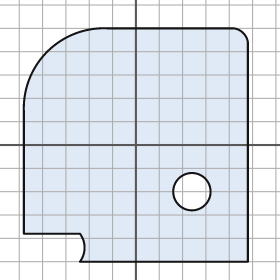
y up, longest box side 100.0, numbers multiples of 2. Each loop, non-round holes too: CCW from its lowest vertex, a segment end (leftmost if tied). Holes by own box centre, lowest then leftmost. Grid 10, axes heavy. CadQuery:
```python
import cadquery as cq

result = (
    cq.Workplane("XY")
    .moveTo(-24.0, -50.0)
    .lineTo(48.0, -50.0)
    .lineTo(48.0, 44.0)
    .threePointArc((46.0, 48.0), (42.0, 50.0))
    .lineTo(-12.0, 50.0)
    .threePointArc((-38.0, 40.0), (-48.0, 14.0))
    .lineTo(-48.0, -38.0)
    .lineTo(-24.0, -38.0)
    .threePointArc((-22.0, -44.0), (-24.0, -50.0))
    .close()
    .moveTo(24.0, -20.0)
    .circle(8.0)
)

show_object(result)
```